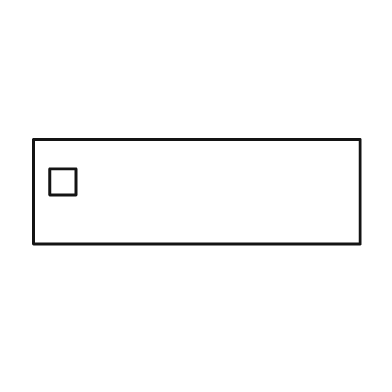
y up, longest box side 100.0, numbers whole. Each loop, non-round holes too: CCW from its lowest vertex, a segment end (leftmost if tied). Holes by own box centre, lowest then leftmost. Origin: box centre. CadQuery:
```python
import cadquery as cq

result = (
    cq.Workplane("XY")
    .moveTo(-50.0, -16.0)
    .lineTo(50.0, -16.0)
    .lineTo(50.0, 16.0)
    .lineTo(-50.0, 16.0)
    .close()
    .moveTo(-45.0, -1.0)
    .lineTo(-37.0, -1.0)
    .lineTo(-37.0, 7.0)
    .lineTo(-45.0, 7.0)
    .close()
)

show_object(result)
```